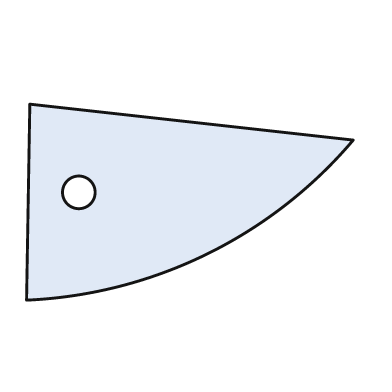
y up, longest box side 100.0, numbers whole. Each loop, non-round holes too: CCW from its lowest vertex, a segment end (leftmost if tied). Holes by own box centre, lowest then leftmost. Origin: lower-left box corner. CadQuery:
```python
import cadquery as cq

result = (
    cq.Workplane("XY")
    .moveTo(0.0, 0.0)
    .threePointArc((55.0, 14.0), (100.0, 49.0))
    .lineTo(1.0, 60.0)
    .close()
    .moveTo(16.0, 33.0)
    .circle(5.0)
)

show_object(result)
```